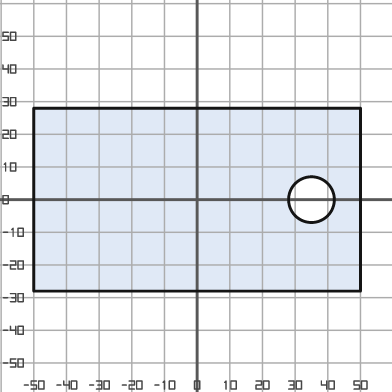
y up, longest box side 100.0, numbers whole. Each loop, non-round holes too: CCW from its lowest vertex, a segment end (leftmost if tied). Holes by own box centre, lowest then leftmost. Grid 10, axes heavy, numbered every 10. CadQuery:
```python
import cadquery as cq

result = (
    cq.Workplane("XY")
    .moveTo(-50.0, -28.0)
    .lineTo(50.0, -28.0)
    .lineTo(50.0, 28.0)
    .lineTo(-50.0, 28.0)
    .close()
    .moveTo(35.0, 0.0)
    .circle(7.0)
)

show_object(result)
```